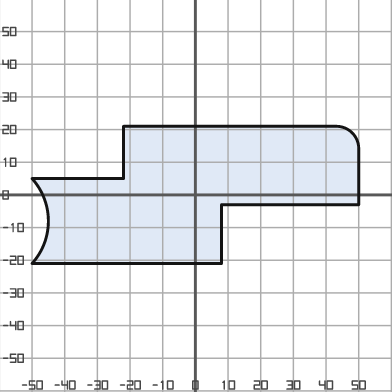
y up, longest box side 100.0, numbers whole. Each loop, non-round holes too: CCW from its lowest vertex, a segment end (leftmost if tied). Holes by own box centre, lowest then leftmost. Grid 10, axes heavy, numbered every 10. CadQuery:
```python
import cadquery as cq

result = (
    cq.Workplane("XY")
    .moveTo(-50.0, -21.0)
    .lineTo(8.0, -21.0)
    .lineTo(8.0, -3.0)
    .lineTo(50.0, -3.0)
    .lineTo(50.0, 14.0)
    .threePointArc((48.0, 19.0), (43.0, 21.0))
    .lineTo(-22.0, 21.0)
    .lineTo(-22.0, 5.0)
    .lineTo(-50.0, 5.0)
    .threePointArc((-45.0, -8.0), (-50.0, -21.0))
    .close()
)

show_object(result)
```